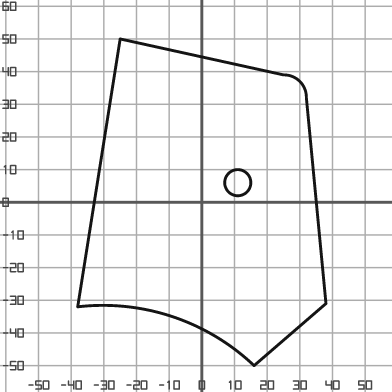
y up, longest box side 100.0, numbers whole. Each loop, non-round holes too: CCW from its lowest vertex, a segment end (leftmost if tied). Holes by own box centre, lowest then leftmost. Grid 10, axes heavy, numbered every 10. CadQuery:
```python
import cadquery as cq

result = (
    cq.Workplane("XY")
    .moveTo(16.0, -50.0)
    .lineTo(38.0, -31.0)
    .lineTo(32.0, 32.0)
    .threePointArc((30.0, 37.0), (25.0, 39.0))
    .lineTo(-25.0, 50.0)
    .lineTo(-38.0, -32.0)
    .threePointArc((-9.0, -35.0), (16.0, -50.0))
    .close()
    .moveTo(11.0, 6.0)
    .circle(4.0)
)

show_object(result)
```